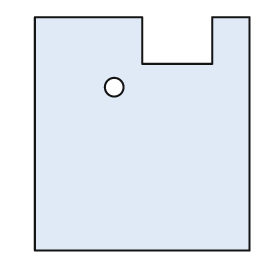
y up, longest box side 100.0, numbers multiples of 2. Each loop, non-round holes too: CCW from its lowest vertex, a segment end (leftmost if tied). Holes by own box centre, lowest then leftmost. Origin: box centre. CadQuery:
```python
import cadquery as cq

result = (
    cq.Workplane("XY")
    .moveTo(-46.0, -50.0)
    .lineTo(46.0, -50.0)
    .lineTo(46.0, 50.0)
    .lineTo(30.0, 50.0)
    .lineTo(30.0, 30.0)
    .lineTo(0.0, 30.0)
    .lineTo(0.0, 50.0)
    .lineTo(-46.0, 50.0)
    .close()
    .moveTo(-12.0, 20.0)
    .circle(4.0)
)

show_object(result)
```